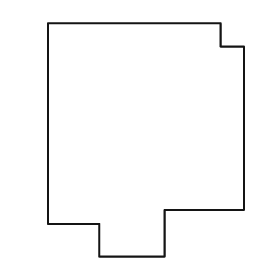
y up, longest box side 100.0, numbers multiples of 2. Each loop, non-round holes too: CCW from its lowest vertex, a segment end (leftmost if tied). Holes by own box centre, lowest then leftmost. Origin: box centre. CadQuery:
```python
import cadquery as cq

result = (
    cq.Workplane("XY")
    .moveTo(-20.0, -50.0)
    .lineTo(8.0, -50.0)
    .lineTo(8.0, -30.0)
    .lineTo(42.0, -30.0)
    .lineTo(42.0, 40.0)
    .lineTo(32.0, 40.0)
    .lineTo(32.0, 50.0)
    .lineTo(-42.0, 50.0)
    .lineTo(-42.0, -36.0)
    .lineTo(-20.0, -36.0)
    .close()
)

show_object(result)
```